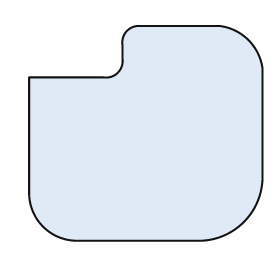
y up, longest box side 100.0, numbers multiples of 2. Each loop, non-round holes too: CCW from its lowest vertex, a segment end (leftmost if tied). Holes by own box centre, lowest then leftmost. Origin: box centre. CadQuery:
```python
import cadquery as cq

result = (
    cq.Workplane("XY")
    .moveTo(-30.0, -46.0)
    .lineTo(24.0, -46.0)
    .threePointArc((42.0, -38.0), (50.0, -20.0))
    .lineTo(50.0, 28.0)
    .threePointArc((44.0, 40.0), (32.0, 46.0))
    .lineTo(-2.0, 46.0)
    .threePointArc((-8.0, 44.0), (-10.0, 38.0))
    .lineTo(-10.0, 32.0)
    .threePointArc((-12.0, 26.0), (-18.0, 24.0))
    .lineTo(-50.0, 24.0)
    .lineTo(-50.0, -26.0)
    .threePointArc((-44.0, -40.0), (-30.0, -46.0))
    .close()
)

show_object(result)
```